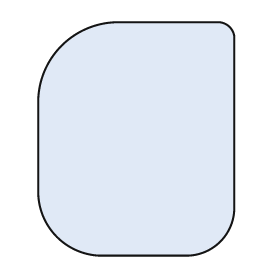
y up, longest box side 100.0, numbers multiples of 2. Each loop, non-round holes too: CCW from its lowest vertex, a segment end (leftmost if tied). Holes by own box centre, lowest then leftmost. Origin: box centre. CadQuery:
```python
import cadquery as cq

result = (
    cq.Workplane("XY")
    .moveTo(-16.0, -50.0)
    .lineTo(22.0, -50.0)
    .threePointArc((36.0, -44.0), (42.0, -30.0))
    .lineTo(42.0, 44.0)
    .threePointArc((40.0, 48.0), (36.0, 50.0))
    .lineTo(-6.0, 50.0)
    .threePointArc((-32.0, 40.0), (-42.0, 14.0))
    .lineTo(-42.0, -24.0)
    .threePointArc((-34.0, -42.0), (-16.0, -50.0))
    .close()
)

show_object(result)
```